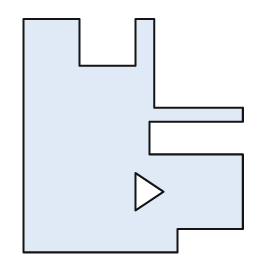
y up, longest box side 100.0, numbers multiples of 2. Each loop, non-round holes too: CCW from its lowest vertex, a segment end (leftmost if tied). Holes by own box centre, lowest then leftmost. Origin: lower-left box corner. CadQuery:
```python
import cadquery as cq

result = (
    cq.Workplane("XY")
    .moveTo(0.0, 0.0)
    .lineTo(66.0, 0.0)
    .lineTo(66.0, 10.0)
    .lineTo(94.0, 10.0)
    .lineTo(94.0, 42.0)
    .lineTo(54.0, 42.0)
    .lineTo(54.0, 56.0)
    .lineTo(94.0, 56.0)
    .lineTo(94.0, 62.0)
    .lineTo(56.0, 62.0)
    .lineTo(56.0, 100.0)
    .lineTo(48.0, 100.0)
    .lineTo(48.0, 80.0)
    .lineTo(24.0, 80.0)
    .lineTo(24.0, 100.0)
    .lineTo(0.0, 100.0)
    .close()
    .moveTo(48.0, 18.0)
    .lineTo(60.0, 26.0)
    .lineTo(48.0, 34.0)
    .close()
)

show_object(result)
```